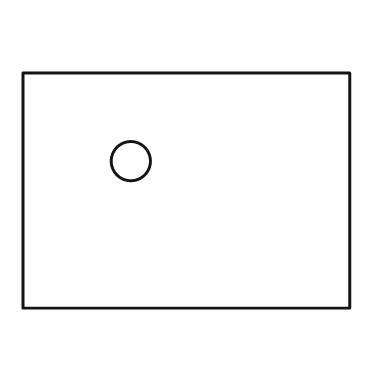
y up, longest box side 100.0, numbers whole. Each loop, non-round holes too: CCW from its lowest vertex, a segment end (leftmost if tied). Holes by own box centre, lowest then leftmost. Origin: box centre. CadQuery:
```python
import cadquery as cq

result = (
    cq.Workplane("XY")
    .moveTo(-50.0, -36.0)
    .lineTo(50.0, -36.0)
    .lineTo(50.0, 36.0)
    .lineTo(-50.0, 36.0)
    .close()
    .moveTo(-17.0, 9.0)
    .circle(6.0)
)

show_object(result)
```